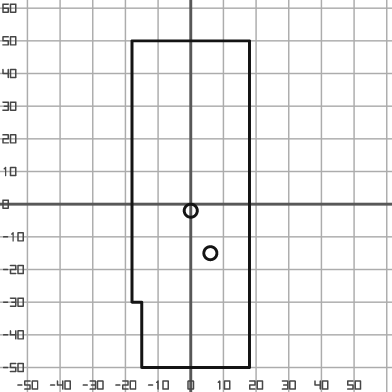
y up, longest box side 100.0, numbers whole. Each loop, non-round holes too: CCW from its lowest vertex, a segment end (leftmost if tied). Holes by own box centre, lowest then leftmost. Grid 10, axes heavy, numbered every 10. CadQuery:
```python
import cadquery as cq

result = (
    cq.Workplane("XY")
    .moveTo(-15.0, -50.0)
    .lineTo(18.0, -50.0)
    .lineTo(18.0, 50.0)
    .lineTo(-18.0, 50.0)
    .lineTo(-18.0, -30.0)
    .lineTo(-15.0, -30.0)
    .close()
    .moveTo(6.0, -15.0)
    .circle(2.0)
    .moveTo(0.0, -2.0)
    .circle(2.0)
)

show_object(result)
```